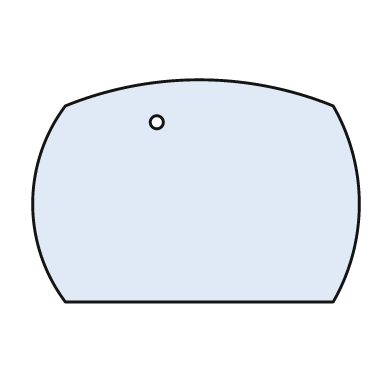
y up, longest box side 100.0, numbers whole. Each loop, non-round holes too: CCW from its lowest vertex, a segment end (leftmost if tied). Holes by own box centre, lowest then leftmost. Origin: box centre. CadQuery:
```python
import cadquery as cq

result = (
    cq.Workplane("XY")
    .moveTo(-40.0, -34.0)
    .lineTo(42.0, -34.0)
    .threePointArc((50.0, -4.0), (42.0, 26.0))
    .threePointArc((1.0, 34.0), (-40.0, 26.0))
    .threePointArc((-50.0, -4.0), (-40.0, -34.0))
    .close()
    .moveTo(-12.0, 21.0)
    .circle(2.0)
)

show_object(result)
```